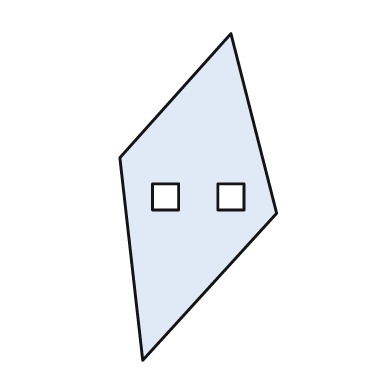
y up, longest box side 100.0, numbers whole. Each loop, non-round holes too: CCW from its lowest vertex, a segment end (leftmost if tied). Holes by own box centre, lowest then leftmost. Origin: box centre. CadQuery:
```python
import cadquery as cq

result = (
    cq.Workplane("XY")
    .moveTo(-17.0, -50.0)
    .lineTo(24.0, -5.0)
    .lineTo(10.0, 50.0)
    .lineTo(-24.0, 12.0)
    .close()
    .moveTo(-14.0, -4.0)
    .lineTo(-6.0, -4.0)
    .lineTo(-6.0, 4.0)
    .lineTo(-14.0, 4.0)
    .close()
    .moveTo(6.0, -4.0)
    .lineTo(14.0, -4.0)
    .lineTo(14.0, 4.0)
    .lineTo(6.0, 4.0)
    .close()
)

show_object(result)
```